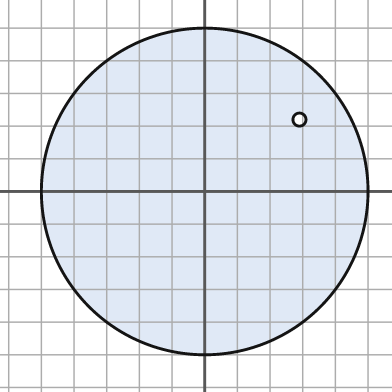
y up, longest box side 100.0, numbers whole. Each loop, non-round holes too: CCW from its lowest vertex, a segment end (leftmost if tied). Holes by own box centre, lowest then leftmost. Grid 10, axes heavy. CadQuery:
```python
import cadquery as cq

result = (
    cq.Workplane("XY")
    .moveTo(0.0, 0.0)
    .circle(50.0)
    .moveTo(29.0, 22.0)
    .circle(2.0)
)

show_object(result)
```